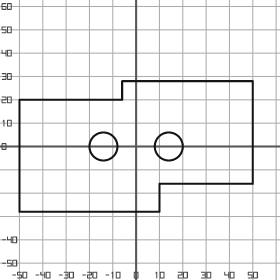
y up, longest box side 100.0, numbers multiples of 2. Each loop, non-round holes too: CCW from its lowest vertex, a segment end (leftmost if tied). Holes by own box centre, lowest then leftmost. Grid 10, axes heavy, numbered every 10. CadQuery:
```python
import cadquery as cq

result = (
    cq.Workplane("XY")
    .moveTo(-50.0, -28.0)
    .lineTo(10.0, -28.0)
    .lineTo(10.0, -16.0)
    .lineTo(50.0, -16.0)
    .lineTo(50.0, 28.0)
    .lineTo(-6.0, 28.0)
    .lineTo(-6.0, 20.0)
    .lineTo(-50.0, 20.0)
    .close()
    .moveTo(-14.0, 0.0)
    .circle(6.0)
    .moveTo(14.0, 0.0)
    .circle(6.0)
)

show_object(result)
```